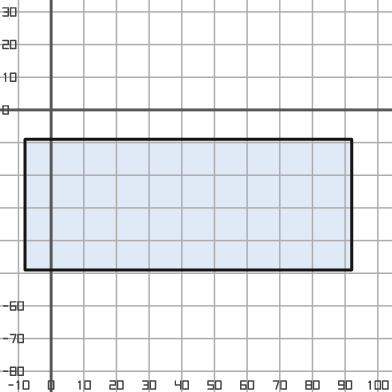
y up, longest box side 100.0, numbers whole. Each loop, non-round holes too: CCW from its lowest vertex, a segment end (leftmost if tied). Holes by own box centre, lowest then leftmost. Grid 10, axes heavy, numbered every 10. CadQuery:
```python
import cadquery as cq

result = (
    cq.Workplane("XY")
    .moveTo(-8.0, -49.0)
    .lineTo(92.0, -49.0)
    .lineTo(92.0, -9.0)
    .lineTo(-8.0, -9.0)
    .close()
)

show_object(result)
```